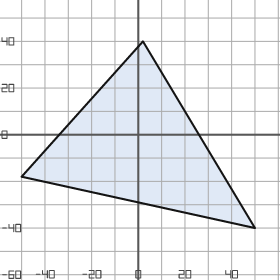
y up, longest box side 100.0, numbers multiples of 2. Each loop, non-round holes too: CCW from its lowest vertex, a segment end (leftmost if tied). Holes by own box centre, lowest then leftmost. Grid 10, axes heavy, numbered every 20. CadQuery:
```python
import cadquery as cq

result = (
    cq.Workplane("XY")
    .moveTo(50.0, -40.0)
    .lineTo(2.0, 40.0)
    .lineTo(-50.0, -18.0)
    .close()
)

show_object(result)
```